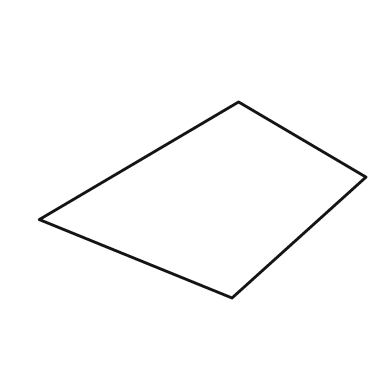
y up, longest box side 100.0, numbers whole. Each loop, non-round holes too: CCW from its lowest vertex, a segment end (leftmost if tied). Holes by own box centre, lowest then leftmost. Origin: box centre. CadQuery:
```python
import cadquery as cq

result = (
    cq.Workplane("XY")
    .moveTo(9.0, -30.0)
    .lineTo(50.0, 7.0)
    .lineTo(11.0, 30.0)
    .lineTo(-50.0, -6.0)
    .close()
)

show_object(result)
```